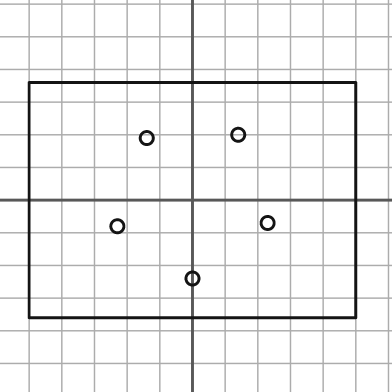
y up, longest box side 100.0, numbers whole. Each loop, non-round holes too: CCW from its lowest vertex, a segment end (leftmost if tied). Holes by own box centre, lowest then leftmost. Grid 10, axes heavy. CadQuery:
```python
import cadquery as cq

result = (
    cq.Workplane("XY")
    .moveTo(-50.0, -36.0)
    .lineTo(50.0, -36.0)
    .lineTo(50.0, 36.0)
    .lineTo(-50.0, 36.0)
    .close()
    .moveTo(0.0, -24.0)
    .circle(2.0)
    .moveTo(-23.0, -8.0)
    .circle(2.0)
    .moveTo(23.0, -7.0)
    .circle(2.0)
    .moveTo(-14.0, 19.0)
    .circle(2.0)
    .moveTo(14.0, 20.0)
    .circle(2.0)
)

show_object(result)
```